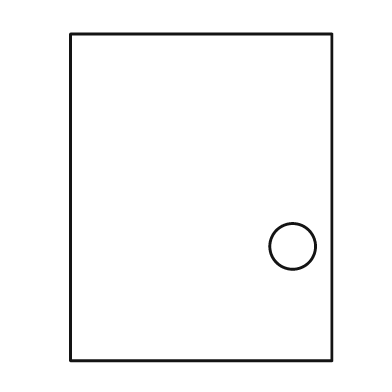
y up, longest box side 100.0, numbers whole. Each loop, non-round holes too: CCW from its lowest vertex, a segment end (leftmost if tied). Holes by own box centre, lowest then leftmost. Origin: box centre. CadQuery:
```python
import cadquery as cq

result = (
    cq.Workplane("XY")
    .moveTo(-40.0, -50.0)
    .lineTo(40.0, -50.0)
    .lineTo(40.0, 50.0)
    .lineTo(-40.0, 50.0)
    .close()
    .moveTo(28.0, -15.0)
    .circle(7.0)
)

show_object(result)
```